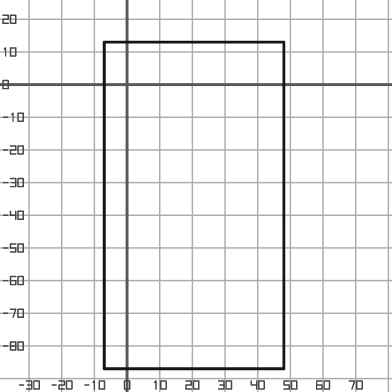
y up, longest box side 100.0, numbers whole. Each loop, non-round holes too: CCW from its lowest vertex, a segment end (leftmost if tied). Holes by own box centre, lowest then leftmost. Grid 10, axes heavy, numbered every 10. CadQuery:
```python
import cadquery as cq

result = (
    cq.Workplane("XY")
    .moveTo(-7.0, -87.0)
    .lineTo(48.0, -87.0)
    .lineTo(48.0, 13.0)
    .lineTo(-7.0, 13.0)
    .close()
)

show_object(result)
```